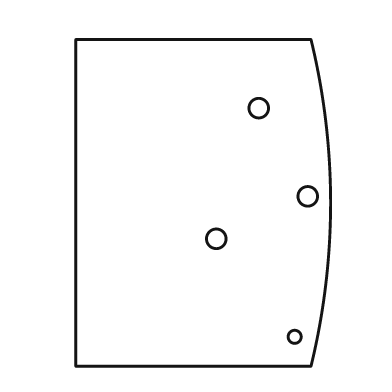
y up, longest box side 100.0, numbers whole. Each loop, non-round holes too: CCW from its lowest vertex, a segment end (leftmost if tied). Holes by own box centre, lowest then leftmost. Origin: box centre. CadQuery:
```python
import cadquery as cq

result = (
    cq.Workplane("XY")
    .moveTo(-39.0, -50.0)
    .lineTo(33.0, -50.0)
    .threePointArc((39.0, 0.0), (33.0, 50.0))
    .lineTo(-39.0, 50.0)
    .close()
    .moveTo(28.0, -41.0)
    .circle(2.0)
    .moveTo(4.0, -11.0)
    .circle(3.0)
    .moveTo(32.0, 2.0)
    .circle(3.0)
    .moveTo(17.0, 29.0)
    .circle(3.0)
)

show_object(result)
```